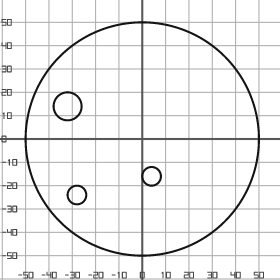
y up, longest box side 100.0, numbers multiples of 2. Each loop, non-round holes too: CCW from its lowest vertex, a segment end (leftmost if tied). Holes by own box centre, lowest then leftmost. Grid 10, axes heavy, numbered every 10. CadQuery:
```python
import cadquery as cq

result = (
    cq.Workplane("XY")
    .moveTo(0.0, 0.0)
    .circle(50.0)
    .moveTo(-28.0, -24.0)
    .circle(4.0)
    .moveTo(4.0, -16.0)
    .circle(4.0)
    .moveTo(-32.0, 14.0)
    .circle(6.0)
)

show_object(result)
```